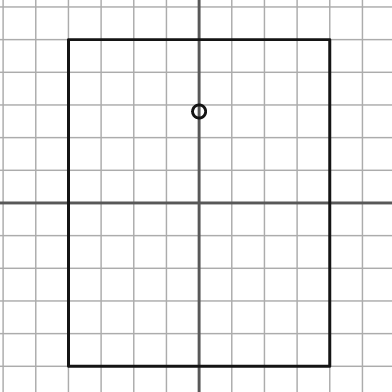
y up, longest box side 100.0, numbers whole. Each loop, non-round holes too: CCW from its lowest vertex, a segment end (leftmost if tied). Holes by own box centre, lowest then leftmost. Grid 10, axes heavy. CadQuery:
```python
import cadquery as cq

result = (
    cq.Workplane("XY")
    .moveTo(-40.0, -50.0)
    .lineTo(40.0, -50.0)
    .lineTo(40.0, 50.0)
    .lineTo(-40.0, 50.0)
    .close()
    .moveTo(0.0, 28.0)
    .circle(2.0)
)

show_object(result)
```